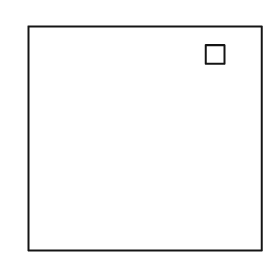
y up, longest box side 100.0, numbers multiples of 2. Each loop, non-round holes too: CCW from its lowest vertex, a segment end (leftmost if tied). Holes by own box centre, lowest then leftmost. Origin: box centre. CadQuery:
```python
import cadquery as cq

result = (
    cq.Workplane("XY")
    .moveTo(-50.0, -48.0)
    .lineTo(50.0, -48.0)
    .lineTo(50.0, 48.0)
    .lineTo(-50.0, 48.0)
    .close()
    .moveTo(26.0, 32.0)
    .lineTo(34.0, 32.0)
    .lineTo(34.0, 40.0)
    .lineTo(26.0, 40.0)
    .close()
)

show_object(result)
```